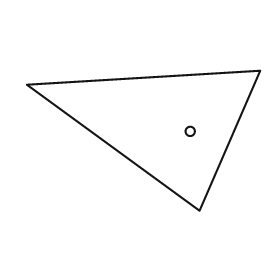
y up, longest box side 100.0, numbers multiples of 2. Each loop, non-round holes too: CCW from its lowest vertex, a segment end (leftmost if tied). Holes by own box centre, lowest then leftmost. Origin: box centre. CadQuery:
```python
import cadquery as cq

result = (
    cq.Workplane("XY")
    .moveTo(24.0, -30.0)
    .lineTo(50.0, 30.0)
    .lineTo(-50.0, 24.0)
    .close()
    .moveTo(20.0, 4.0)
    .circle(2.0)
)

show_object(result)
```